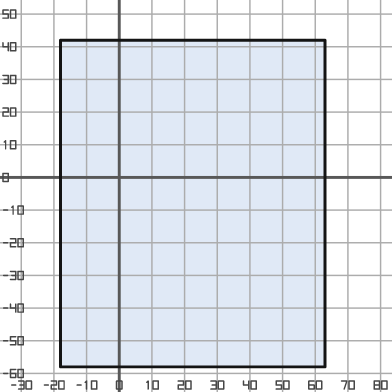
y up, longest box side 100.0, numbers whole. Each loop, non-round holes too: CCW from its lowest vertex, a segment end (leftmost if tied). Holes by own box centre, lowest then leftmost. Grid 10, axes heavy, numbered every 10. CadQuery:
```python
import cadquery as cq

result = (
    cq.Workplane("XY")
    .moveTo(-18.0, -58.0)
    .lineTo(63.0, -58.0)
    .lineTo(63.0, 42.0)
    .lineTo(-18.0, 42.0)
    .close()
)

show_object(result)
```